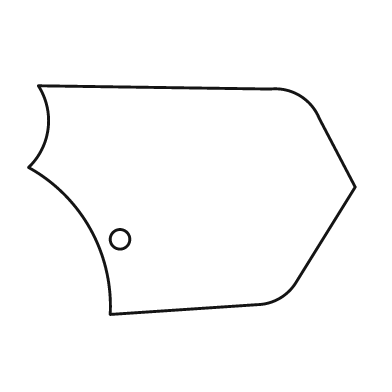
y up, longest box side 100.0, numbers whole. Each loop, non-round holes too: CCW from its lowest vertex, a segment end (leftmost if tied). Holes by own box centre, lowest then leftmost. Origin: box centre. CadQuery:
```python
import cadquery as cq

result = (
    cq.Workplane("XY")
    .moveTo(-25.0, -35.0)
    .lineTo(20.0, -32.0)
    .threePointArc((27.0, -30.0), (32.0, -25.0))
    .lineTo(50.0, 4.0)
    .lineTo(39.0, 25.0)
    .threePointArc((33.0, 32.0), (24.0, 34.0))
    .lineTo(-47.0, 35.0)
    .threePointArc((-44.0, 22.0), (-50.0, 10.0))
    .threePointArc((-31.0, -9.0), (-25.0, -35.0))
    .close()
    .moveTo(-22.0, -12.0)
    .circle(3.0)
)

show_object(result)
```